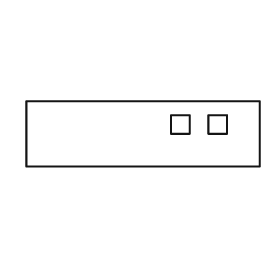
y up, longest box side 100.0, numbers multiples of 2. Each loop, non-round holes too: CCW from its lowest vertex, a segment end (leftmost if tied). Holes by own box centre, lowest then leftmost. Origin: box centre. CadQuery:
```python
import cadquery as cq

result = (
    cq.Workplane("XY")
    .moveTo(-50.0, -14.0)
    .lineTo(50.0, -14.0)
    .lineTo(50.0, 14.0)
    .lineTo(-50.0, 14.0)
    .close()
    .moveTo(12.0, 0.0)
    .lineTo(20.0, 0.0)
    .lineTo(20.0, 8.0)
    .lineTo(12.0, 8.0)
    .close()
    .moveTo(28.0, 0.0)
    .lineTo(36.0, 0.0)
    .lineTo(36.0, 8.0)
    .lineTo(28.0, 8.0)
    .close()
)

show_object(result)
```